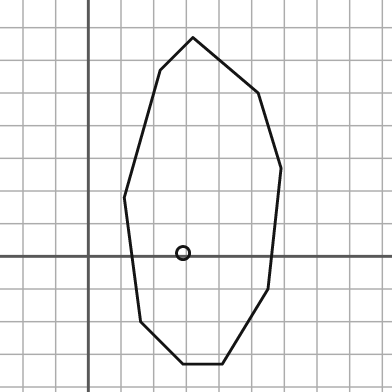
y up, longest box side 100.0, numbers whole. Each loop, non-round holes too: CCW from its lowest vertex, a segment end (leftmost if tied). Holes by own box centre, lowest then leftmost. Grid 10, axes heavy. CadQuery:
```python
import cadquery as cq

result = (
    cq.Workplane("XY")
    .moveTo(29.0, -33.0)
    .lineTo(41.0, -33.0)
    .lineTo(55.0, -10.0)
    .lineTo(59.0, 27.0)
    .lineTo(52.0, 50.0)
    .lineTo(32.0, 67.0)
    .lineTo(22.0, 57.0)
    .lineTo(11.0, 18.0)
    .lineTo(16.0, -20.0)
    .close()
    .moveTo(29.0, 1.0)
    .circle(2.0)
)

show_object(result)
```